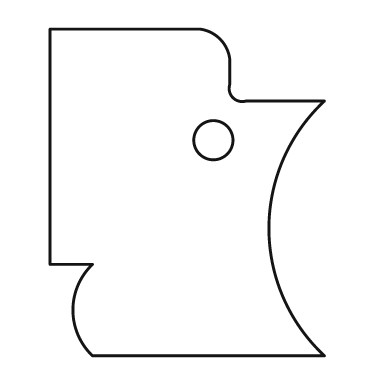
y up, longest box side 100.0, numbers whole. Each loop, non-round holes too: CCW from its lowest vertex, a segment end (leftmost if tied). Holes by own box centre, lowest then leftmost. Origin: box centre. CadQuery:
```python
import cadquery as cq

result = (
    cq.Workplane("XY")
    .moveTo(-29.0, -50.0)
    .lineTo(42.0, -50.0)
    .threePointArc((25.0, -11.0), (42.0, 28.0))
    .lineTo(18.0, 28.0)
    .threePointArc((14.0, 29.0), (13.0, 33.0))
    .lineTo(13.0, 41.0)
    .threePointArc((10.0, 47.0), (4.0, 50.0))
    .lineTo(-42.0, 50.0)
    .lineTo(-42.0, -22.0)
    .lineTo(-29.0, -22.0)
    .threePointArc((-35.0, -36.0), (-29.0, -50.0))
    .close()
    .moveTo(8.0, 16.0)
    .circle(6.0)
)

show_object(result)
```